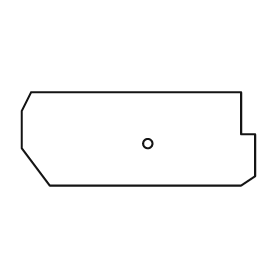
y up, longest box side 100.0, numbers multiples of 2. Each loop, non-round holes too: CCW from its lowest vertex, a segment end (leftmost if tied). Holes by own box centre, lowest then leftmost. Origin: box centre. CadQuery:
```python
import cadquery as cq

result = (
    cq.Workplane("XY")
    .moveTo(-38.0, -20.0)
    .lineTo(44.0, -20.0)
    .lineTo(50.0, -16.0)
    .lineTo(50.0, 2.0)
    .lineTo(44.0, 2.0)
    .lineTo(44.0, 20.0)
    .lineTo(-46.0, 20.0)
    .lineTo(-50.0, 12.0)
    .lineTo(-50.0, -4.0)
    .close()
    .moveTo(4.0, -2.0)
    .circle(2.0)
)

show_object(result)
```